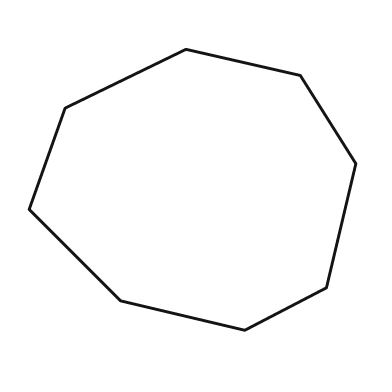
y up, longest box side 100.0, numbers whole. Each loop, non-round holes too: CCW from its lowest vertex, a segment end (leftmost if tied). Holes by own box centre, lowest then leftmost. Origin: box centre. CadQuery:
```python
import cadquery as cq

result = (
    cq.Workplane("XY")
    .moveTo(16.0, -43.0)
    .lineTo(41.0, -30.0)
    .lineTo(50.0, 8.0)
    .lineTo(33.0, 35.0)
    .lineTo(-2.0, 43.0)
    .lineTo(-39.0, 25.0)
    .lineTo(-50.0, -6.0)
    .lineTo(-22.0, -34.0)
    .close()
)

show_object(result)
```